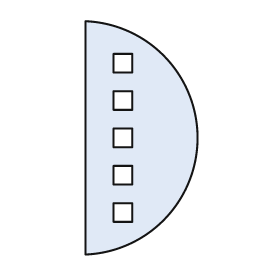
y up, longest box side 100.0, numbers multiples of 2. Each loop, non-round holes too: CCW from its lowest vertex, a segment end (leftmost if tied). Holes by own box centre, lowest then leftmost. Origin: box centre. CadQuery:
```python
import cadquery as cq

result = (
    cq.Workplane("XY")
    .moveTo(-24.0, -50.0)
    .threePointArc((24.0, 0.0), (-24.0, 50.0))
    .close()
    .moveTo(-12.0, -36.0)
    .lineTo(-4.0, -36.0)
    .lineTo(-4.0, -28.0)
    .lineTo(-12.0, -28.0)
    .close()
    .moveTo(-12.0, -20.0)
    .lineTo(-4.0, -20.0)
    .lineTo(-4.0, -12.0)
    .lineTo(-12.0, -12.0)
    .close()
    .moveTo(-12.0, -4.0)
    .lineTo(-4.0, -4.0)
    .lineTo(-4.0, 4.0)
    .lineTo(-12.0, 4.0)
    .close()
    .moveTo(-12.0, 12.0)
    .lineTo(-4.0, 12.0)
    .lineTo(-4.0, 20.0)
    .lineTo(-12.0, 20.0)
    .close()
    .moveTo(-12.0, 28.0)
    .lineTo(-4.0, 28.0)
    .lineTo(-4.0, 36.0)
    .lineTo(-12.0, 36.0)
    .close()
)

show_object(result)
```